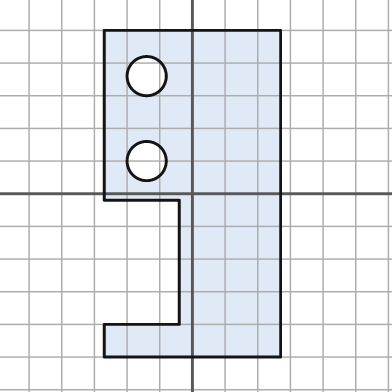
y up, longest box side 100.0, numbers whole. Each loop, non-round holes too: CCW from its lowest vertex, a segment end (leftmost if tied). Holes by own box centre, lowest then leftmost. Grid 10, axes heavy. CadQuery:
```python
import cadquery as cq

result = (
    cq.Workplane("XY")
    .moveTo(-27.0, -50.0)
    .lineTo(27.0, -50.0)
    .lineTo(27.0, 50.0)
    .lineTo(-27.0, 50.0)
    .lineTo(-27.0, -2.0)
    .lineTo(-4.0, -2.0)
    .lineTo(-4.0, -40.0)
    .lineTo(-27.0, -40.0)
    .close()
    .moveTo(-14.0, 10.0)
    .circle(6.0)
    .moveTo(-14.0, 36.0)
    .circle(6.0)
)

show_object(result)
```